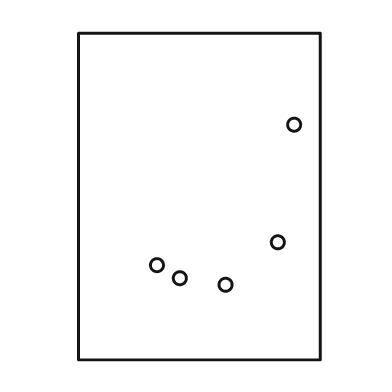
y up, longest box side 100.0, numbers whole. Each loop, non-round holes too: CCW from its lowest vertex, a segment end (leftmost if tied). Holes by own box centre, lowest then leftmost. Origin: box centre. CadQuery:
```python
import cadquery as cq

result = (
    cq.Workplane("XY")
    .moveTo(-37.0, -50.0)
    .lineTo(37.0, -50.0)
    .lineTo(37.0, 50.0)
    .lineTo(-37.0, 50.0)
    .close()
    .moveTo(8.0, -27.0)
    .circle(2.0)
    .moveTo(-6.0, -25.0)
    .circle(2.0)
    .moveTo(-13.0, -21.0)
    .circle(2.0)
    .moveTo(24.0, -14.0)
    .circle(2.0)
    .moveTo(29.0, 22.0)
    .circle(2.0)
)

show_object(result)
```